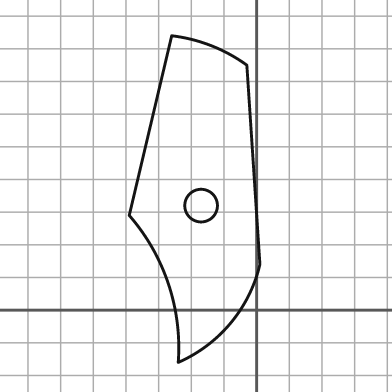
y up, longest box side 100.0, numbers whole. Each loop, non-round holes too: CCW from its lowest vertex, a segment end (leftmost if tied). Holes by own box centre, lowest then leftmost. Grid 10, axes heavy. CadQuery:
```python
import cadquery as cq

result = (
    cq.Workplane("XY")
    .moveTo(-24.0, -16.0)
    .threePointArc((-8.0, -4.0), (1.0, 14.0))
    .lineTo(-3.0, 75.0)
    .threePointArc((-14.0, 81.0), (-26.0, 84.0))
    .lineTo(-39.0, 29.0)
    .threePointArc((-27.0, 8.0), (-24.0, -16.0))
    .close()
    .moveTo(-17.0, 32.0)
    .circle(5.0)
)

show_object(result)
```